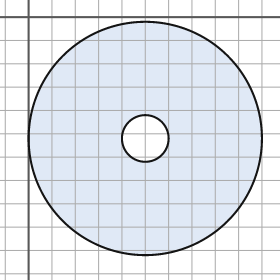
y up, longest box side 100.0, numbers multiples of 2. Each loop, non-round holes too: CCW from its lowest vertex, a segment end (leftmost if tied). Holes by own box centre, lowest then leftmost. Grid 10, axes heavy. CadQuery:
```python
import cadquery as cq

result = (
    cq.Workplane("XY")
    .moveTo(50.0, -52.0)
    .circle(50.0)
    .moveTo(50.0, -52.0)
    .circle(10.0)
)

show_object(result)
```